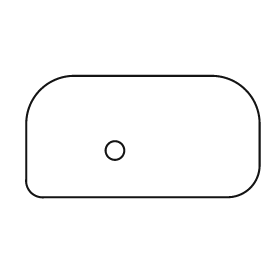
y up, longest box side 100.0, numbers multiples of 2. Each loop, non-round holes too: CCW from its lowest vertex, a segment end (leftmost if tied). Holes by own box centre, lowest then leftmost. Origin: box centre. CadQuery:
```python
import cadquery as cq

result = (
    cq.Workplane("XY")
    .moveTo(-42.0, -26.0)
    .lineTo(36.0, -26.0)
    .threePointArc((46.0, -22.0), (50.0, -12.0))
    .lineTo(50.0, 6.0)
    .threePointArc((44.0, 20.0), (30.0, 26.0))
    .lineTo(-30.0, 26.0)
    .threePointArc((-44.0, 20.0), (-50.0, 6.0))
    .lineTo(-50.0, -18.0)
    .threePointArc((-48.0, -24.0), (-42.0, -26.0))
    .close()
    .moveTo(-12.0, -6.0)
    .circle(4.0)
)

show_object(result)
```